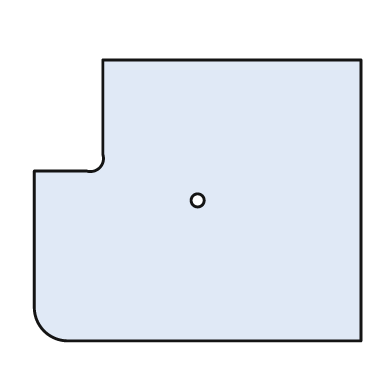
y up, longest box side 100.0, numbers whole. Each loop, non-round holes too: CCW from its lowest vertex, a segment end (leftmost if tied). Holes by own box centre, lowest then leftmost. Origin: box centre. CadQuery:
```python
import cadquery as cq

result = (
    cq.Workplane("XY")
    .moveTo(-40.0, -43.0)
    .lineTo(50.0, -43.0)
    .lineTo(50.0, 43.0)
    .lineTo(-29.0, 43.0)
    .lineTo(-29.0, 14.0)
    .threePointArc((-30.0, 10.0), (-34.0, 9.0))
    .lineTo(-50.0, 9.0)
    .lineTo(-50.0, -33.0)
    .threePointArc((-47.0, -40.0), (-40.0, -43.0))
    .close()
    .moveTo(0.0, 0.0)
    .circle(2.0)
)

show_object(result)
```